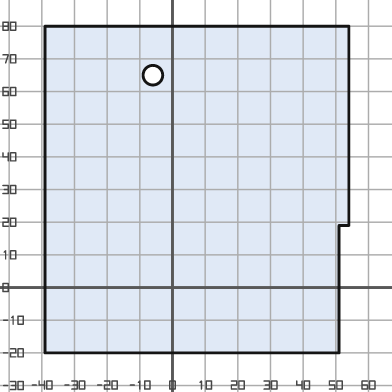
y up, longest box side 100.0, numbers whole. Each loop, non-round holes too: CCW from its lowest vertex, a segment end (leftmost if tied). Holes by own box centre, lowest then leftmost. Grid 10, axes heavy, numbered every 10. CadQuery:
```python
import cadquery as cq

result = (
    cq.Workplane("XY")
    .moveTo(-39.0, -20.0)
    .lineTo(51.0, -20.0)
    .lineTo(51.0, 19.0)
    .lineTo(54.0, 19.0)
    .lineTo(54.0, 80.0)
    .lineTo(-39.0, 80.0)
    .close()
    .moveTo(-6.0, 65.0)
    .circle(3.0)
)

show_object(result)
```